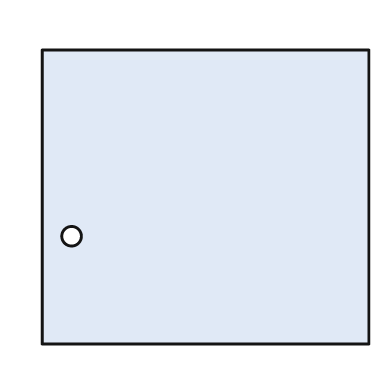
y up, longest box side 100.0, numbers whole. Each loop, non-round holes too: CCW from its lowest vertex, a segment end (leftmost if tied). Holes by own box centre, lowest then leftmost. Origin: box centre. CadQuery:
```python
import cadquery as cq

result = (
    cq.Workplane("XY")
    .moveTo(-50.0, -45.0)
    .lineTo(50.0, -45.0)
    .lineTo(50.0, 45.0)
    .lineTo(-50.0, 45.0)
    .close()
    .moveTo(-41.0, -12.0)
    .circle(3.0)
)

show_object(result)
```